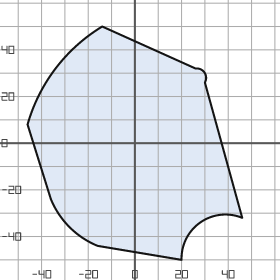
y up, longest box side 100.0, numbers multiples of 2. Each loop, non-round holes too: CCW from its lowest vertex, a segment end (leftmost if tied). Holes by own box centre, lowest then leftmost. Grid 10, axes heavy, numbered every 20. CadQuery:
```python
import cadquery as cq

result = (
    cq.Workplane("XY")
    .moveTo(20.0, -50.0)
    .threePointArc((28.0, -34.0), (46.0, -32.0))
    .lineTo(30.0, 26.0)
    .threePointArc((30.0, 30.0), (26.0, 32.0))
    .lineTo(-14.0, 50.0)
    .threePointArc((-34.0, 32.0), (-46.0, 8.0))
    .lineTo(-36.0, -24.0)
    .threePointArc((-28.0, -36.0), (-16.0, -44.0))
    .close()
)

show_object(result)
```